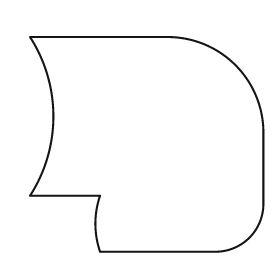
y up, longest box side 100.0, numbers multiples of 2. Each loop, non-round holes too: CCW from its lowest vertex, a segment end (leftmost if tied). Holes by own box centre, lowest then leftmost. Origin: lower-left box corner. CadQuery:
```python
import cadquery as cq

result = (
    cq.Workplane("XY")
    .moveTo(30.0, 0.0)
    .lineTo(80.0, 0.0)
    .threePointArc((94.0, 6.0), (100.0, 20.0))
    .lineTo(100.0, 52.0)
    .threePointArc((88.0, 80.0), (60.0, 92.0))
    .lineTo(0.0, 92.0)
    .threePointArc((10.0, 58.0), (0.0, 24.0))
    .lineTo(30.0, 24.0)
    .threePointArc((28.0, 12.0), (30.0, 0.0))
    .close()
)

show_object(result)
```